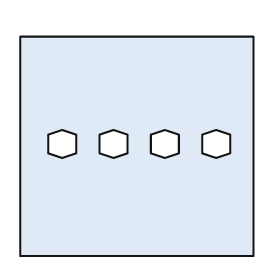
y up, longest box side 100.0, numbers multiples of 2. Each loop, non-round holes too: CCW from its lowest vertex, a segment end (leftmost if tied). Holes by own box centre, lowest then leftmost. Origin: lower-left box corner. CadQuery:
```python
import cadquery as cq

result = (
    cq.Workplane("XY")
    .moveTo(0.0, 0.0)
    .lineTo(100.0, 0.0)
    .lineTo(100.0, 94.0)
    .lineTo(0.0, 94.0)
    .close()
    .moveTo(18.0, 42.0)
    .lineTo(24.0, 44.0)
    .lineTo(24.0, 52.0)
    .lineTo(18.0, 54.0)
    .lineTo(12.0, 52.0)
    .lineTo(12.0, 44.0)
    .close()
    .moveTo(40.0, 42.0)
    .lineTo(46.0, 44.0)
    .lineTo(46.0, 52.0)
    .lineTo(40.0, 54.0)
    .lineTo(34.0, 52.0)
    .lineTo(34.0, 44.0)
    .close()
    .moveTo(62.0, 42.0)
    .lineTo(68.0, 44.0)
    .lineTo(68.0, 52.0)
    .lineTo(62.0, 54.0)
    .lineTo(56.0, 52.0)
    .lineTo(56.0, 44.0)
    .close()
    .moveTo(84.0, 42.0)
    .lineTo(90.0, 44.0)
    .lineTo(90.0, 52.0)
    .lineTo(84.0, 54.0)
    .lineTo(78.0, 52.0)
    .lineTo(78.0, 44.0)
    .close()
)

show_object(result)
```